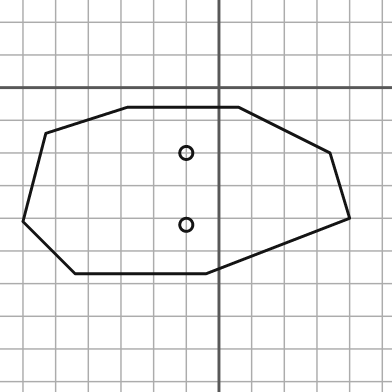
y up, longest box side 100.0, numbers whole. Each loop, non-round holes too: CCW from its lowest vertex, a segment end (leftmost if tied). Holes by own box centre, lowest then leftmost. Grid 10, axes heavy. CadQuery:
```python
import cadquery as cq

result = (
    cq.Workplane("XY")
    .moveTo(-44.0, -57.0)
    .lineTo(-4.0, -57.0)
    .lineTo(40.0, -40.0)
    .lineTo(34.0, -20.0)
    .lineTo(6.0, -6.0)
    .lineTo(-28.0, -6.0)
    .lineTo(-53.0, -14.0)
    .lineTo(-60.0, -41.0)
    .close()
    .moveTo(-10.0, -42.0)
    .circle(2.0)
    .moveTo(-10.0, -20.0)
    .circle(2.0)
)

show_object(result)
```